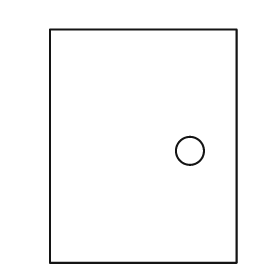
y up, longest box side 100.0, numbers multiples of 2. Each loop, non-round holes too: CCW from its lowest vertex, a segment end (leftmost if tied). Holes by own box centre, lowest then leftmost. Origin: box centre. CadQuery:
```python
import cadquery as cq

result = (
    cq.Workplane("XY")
    .moveTo(-40.0, -50.0)
    .lineTo(40.0, -50.0)
    .lineTo(40.0, 50.0)
    .lineTo(-40.0, 50.0)
    .close()
    .moveTo(20.0, -2.0)
    .circle(6.0)
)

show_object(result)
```